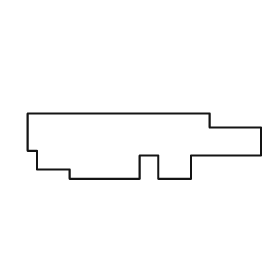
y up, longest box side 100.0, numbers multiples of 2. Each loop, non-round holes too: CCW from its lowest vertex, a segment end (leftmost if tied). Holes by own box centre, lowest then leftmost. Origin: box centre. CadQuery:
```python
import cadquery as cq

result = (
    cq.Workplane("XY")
    .moveTo(-32.0, -14.0)
    .lineTo(-2.0, -14.0)
    .lineTo(-2.0, -4.0)
    .lineTo(6.0, -4.0)
    .lineTo(6.0, -14.0)
    .lineTo(20.0, -14.0)
    .lineTo(20.0, -4.0)
    .lineTo(50.0, -4.0)
    .lineTo(50.0, 8.0)
    .lineTo(28.0, 8.0)
    .lineTo(28.0, 14.0)
    .lineTo(-50.0, 14.0)
    .lineTo(-50.0, -2.0)
    .lineTo(-46.0, -2.0)
    .lineTo(-46.0, -10.0)
    .lineTo(-32.0, -10.0)
    .close()
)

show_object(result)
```